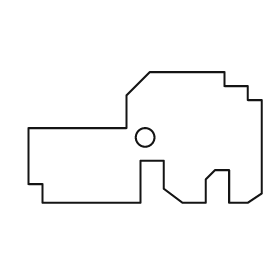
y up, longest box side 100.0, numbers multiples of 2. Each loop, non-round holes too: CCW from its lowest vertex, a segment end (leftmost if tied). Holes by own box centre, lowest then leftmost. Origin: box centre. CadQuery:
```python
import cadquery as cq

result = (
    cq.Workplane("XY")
    .moveTo(-44.0, -28.0)
    .lineTo(-2.0, -28.0)
    .lineTo(-2.0, -10.0)
    .lineTo(8.0, -10.0)
    .lineTo(8.0, -22.0)
    .lineTo(16.0, -28.0)
    .lineTo(26.0, -28.0)
    .lineTo(26.0, -18.0)
    .lineTo(30.0, -14.0)
    .lineTo(36.0, -14.0)
    .lineTo(36.0, -28.0)
    .lineTo(44.0, -28.0)
    .lineTo(50.0, -24.0)
    .lineTo(50.0, 16.0)
    .lineTo(44.0, 16.0)
    .lineTo(44.0, 22.0)
    .lineTo(34.0, 22.0)
    .lineTo(34.0, 28.0)
    .lineTo(2.0, 28.0)
    .lineTo(-8.0, 18.0)
    .lineTo(-8.0, 4.0)
    .lineTo(-50.0, 4.0)
    .lineTo(-50.0, -20.0)
    .lineTo(-44.0, -20.0)
    .close()
    .moveTo(0.0, 0.0)
    .circle(4.0)
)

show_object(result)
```